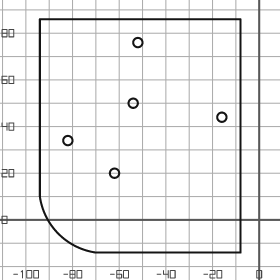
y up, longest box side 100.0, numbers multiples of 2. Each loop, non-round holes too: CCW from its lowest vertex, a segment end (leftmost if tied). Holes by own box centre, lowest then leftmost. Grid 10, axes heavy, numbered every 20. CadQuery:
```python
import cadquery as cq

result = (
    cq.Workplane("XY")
    .moveTo(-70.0, -14.0)
    .lineTo(-8.0, -14.0)
    .lineTo(-8.0, 86.0)
    .lineTo(-94.0, 86.0)
    .lineTo(-94.0, 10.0)
    .threePointArc((-86.0, -6.0), (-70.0, -14.0))
    .close()
    .moveTo(-62.0, 20.0)
    .circle(2.0)
    .moveTo(-82.0, 34.0)
    .circle(2.0)
    .moveTo(-16.0, 44.0)
    .circle(2.0)
    .moveTo(-54.0, 50.0)
    .circle(2.0)
    .moveTo(-52.0, 76.0)
    .circle(2.0)
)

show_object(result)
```